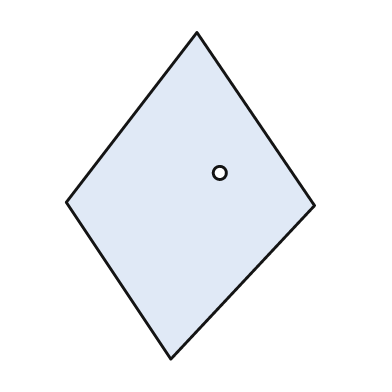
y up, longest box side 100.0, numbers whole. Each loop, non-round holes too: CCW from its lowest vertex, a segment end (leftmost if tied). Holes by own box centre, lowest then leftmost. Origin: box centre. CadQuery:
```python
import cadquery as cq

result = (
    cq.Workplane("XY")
    .moveTo(-6.0, -50.0)
    .lineTo(38.0, -3.0)
    .lineTo(2.0, 50.0)
    .lineTo(-38.0, -2.0)
    .close()
    .moveTo(9.0, 7.0)
    .circle(2.0)
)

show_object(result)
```